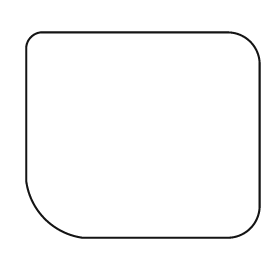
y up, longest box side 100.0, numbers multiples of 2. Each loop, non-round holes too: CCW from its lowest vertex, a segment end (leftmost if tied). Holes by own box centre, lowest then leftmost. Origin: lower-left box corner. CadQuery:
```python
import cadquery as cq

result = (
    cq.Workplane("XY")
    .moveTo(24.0, 0.0)
    .lineTo(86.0, 0.0)
    .threePointArc((96.0, 4.0), (100.0, 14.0))
    .lineTo(100.0, 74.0)
    .threePointArc((96.0, 84.0), (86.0, 88.0))
    .lineTo(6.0, 88.0)
    .threePointArc((2.0, 86.0), (0.0, 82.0))
    .lineTo(0.0, 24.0)
    .threePointArc((8.0, 8.0), (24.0, 0.0))
    .close()
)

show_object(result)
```